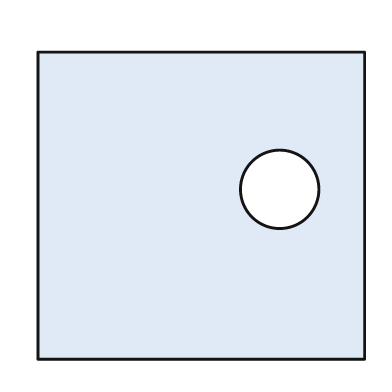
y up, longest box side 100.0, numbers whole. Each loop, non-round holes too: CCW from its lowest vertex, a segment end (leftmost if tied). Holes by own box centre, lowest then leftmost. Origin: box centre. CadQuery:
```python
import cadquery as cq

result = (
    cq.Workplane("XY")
    .moveTo(-50.0, -47.0)
    .lineTo(50.0, -47.0)
    .lineTo(50.0, 47.0)
    .lineTo(-50.0, 47.0)
    .close()
    .moveTo(24.0, 5.0)
    .circle(12.0)
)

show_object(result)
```